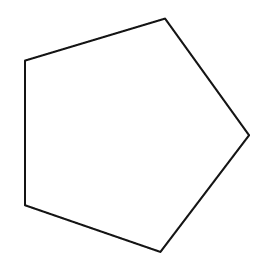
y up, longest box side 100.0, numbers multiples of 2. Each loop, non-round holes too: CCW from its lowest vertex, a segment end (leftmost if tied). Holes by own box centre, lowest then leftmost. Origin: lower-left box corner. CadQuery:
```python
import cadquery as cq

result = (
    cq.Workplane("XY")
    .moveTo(58.0, 0.0)
    .lineTo(96.0, 50.0)
    .lineTo(60.0, 100.0)
    .lineTo(0.0, 82.0)
    .lineTo(0.0, 20.0)
    .close()
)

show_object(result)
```